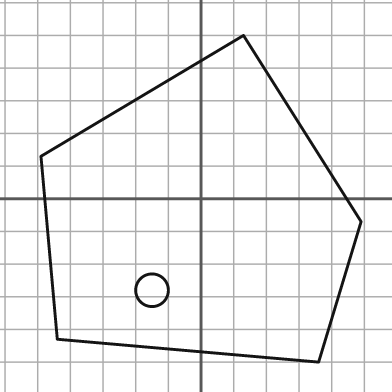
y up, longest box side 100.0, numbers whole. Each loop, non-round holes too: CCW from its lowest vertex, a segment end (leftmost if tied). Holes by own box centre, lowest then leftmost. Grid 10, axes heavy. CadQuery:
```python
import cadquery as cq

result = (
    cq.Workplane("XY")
    .moveTo(36.0, -50.0)
    .lineTo(49.0, -7.0)
    .lineTo(13.0, 50.0)
    .lineTo(-49.0, 13.0)
    .lineTo(-44.0, -43.0)
    .close()
    .moveTo(-15.0, -28.0)
    .circle(5.0)
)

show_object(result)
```